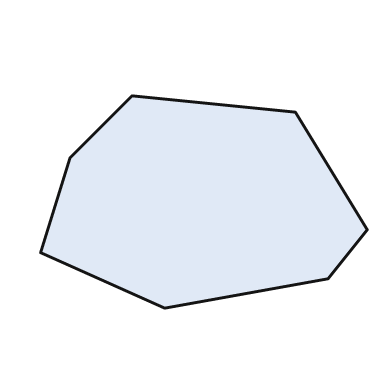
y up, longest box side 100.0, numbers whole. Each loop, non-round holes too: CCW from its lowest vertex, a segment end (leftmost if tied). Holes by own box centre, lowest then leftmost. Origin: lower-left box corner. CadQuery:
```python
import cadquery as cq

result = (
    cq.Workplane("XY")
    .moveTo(38.0, 0.0)
    .lineTo(88.0, 9.0)
    .lineTo(100.0, 24.0)
    .lineTo(78.0, 60.0)
    .lineTo(28.0, 65.0)
    .lineTo(9.0, 46.0)
    .lineTo(0.0, 17.0)
    .close()
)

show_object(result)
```